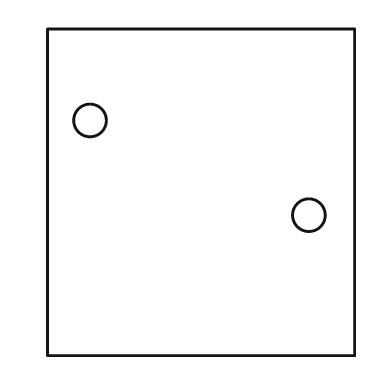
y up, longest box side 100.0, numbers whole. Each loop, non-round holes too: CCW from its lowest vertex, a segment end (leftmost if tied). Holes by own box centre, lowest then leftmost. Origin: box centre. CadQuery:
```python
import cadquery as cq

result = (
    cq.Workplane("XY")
    .moveTo(-47.0, -50.0)
    .lineTo(47.0, -50.0)
    .lineTo(47.0, 50.0)
    .lineTo(-47.0, 50.0)
    .close()
    .moveTo(33.0, -7.0)
    .circle(5.0)
    .moveTo(-34.0, 22.0)
    .circle(5.0)
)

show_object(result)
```